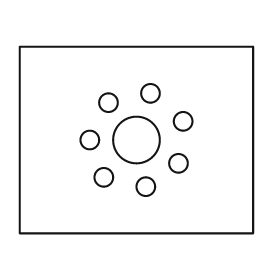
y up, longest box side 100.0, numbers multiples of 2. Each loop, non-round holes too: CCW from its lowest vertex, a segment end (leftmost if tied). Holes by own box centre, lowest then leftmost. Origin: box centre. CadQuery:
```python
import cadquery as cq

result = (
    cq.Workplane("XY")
    .moveTo(-50.0, -40.0)
    .lineTo(50.0, -40.0)
    .lineTo(50.0, 40.0)
    .lineTo(-50.0, 40.0)
    .close()
    .moveTo(4.0, -20.0)
    .circle(4.0)
    .moveTo(-14.0, -16.0)
    .circle(4.0)
    .moveTo(18.0, -10.0)
    .circle(4.0)
    .moveTo(-20.0, 0.0)
    .circle(4.0)
    .moveTo(0.0, 0.0)
    .circle(10.0)
    .moveTo(20.0, 8.0)
    .circle(4.0)
    .moveTo(-12.0, 16.0)
    .circle(4.0)
    .moveTo(6.0, 20.0)
    .circle(4.0)
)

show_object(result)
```